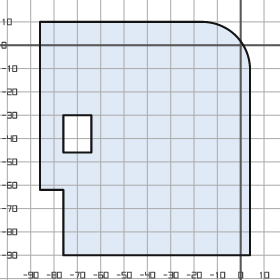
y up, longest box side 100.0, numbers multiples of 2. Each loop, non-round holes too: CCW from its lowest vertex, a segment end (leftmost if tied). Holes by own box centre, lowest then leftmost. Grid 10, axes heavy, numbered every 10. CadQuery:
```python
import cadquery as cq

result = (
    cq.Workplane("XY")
    .moveTo(-76.0, -90.0)
    .lineTo(4.0, -90.0)
    .lineTo(4.0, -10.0)
    .threePointArc((-2.0, 4.0), (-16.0, 10.0))
    .lineTo(-86.0, 10.0)
    .lineTo(-86.0, -62.0)
    .lineTo(-76.0, -62.0)
    .close()
    .moveTo(-76.0, -46.0)
    .lineTo(-64.0, -46.0)
    .lineTo(-64.0, -30.0)
    .lineTo(-76.0, -30.0)
    .close()
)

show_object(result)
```